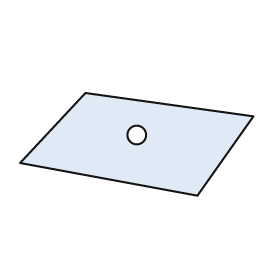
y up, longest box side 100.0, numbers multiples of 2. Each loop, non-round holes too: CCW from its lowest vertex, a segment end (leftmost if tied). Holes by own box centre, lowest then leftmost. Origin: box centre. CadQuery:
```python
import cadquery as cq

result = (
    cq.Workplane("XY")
    .moveTo(26.0, -22.0)
    .lineTo(50.0, 12.0)
    .lineTo(-22.0, 22.0)
    .lineTo(-50.0, -8.0)
    .close()
    .moveTo(0.0, 4.0)
    .circle(4.0)
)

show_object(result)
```